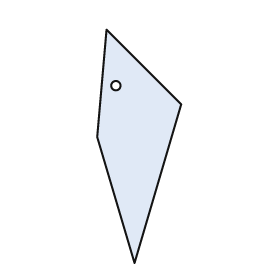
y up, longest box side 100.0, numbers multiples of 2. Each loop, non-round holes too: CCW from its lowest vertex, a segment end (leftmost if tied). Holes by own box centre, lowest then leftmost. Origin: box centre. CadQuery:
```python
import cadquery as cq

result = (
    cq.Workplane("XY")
    .moveTo(-2.0, -50.0)
    .lineTo(18.0, 18.0)
    .lineTo(-14.0, 50.0)
    .lineTo(-18.0, 4.0)
    .close()
    .moveTo(-10.0, 26.0)
    .circle(2.0)
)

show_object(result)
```